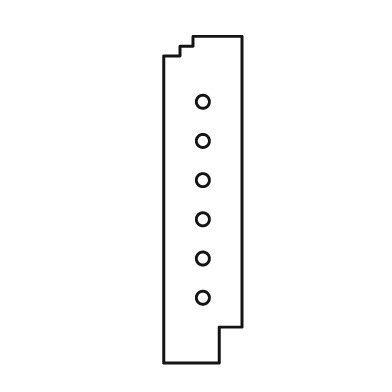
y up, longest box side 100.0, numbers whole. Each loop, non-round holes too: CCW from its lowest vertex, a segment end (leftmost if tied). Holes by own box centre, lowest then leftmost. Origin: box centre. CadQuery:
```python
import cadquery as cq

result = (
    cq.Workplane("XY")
    .moveTo(-12.0, -50.0)
    .lineTo(5.0, -50.0)
    .lineTo(5.0, -39.0)
    .lineTo(12.0, -39.0)
    .lineTo(12.0, 50.0)
    .lineTo(-3.0, 50.0)
    .lineTo(-3.0, 47.0)
    .lineTo(-7.0, 47.0)
    .lineTo(-7.0, 44.0)
    .lineTo(-12.0, 44.0)
    .close()
    .moveTo(0.0, -30.0)
    .circle(2.0)
    .moveTo(0.0, -18.0)
    .circle(2.0)
    .moveTo(0.0, -6.0)
    .circle(2.0)
    .moveTo(0.0, 6.0)
    .circle(2.0)
    .moveTo(0.0, 18.0)
    .circle(2.0)
    .moveTo(0.0, 30.0)
    .circle(2.0)
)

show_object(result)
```